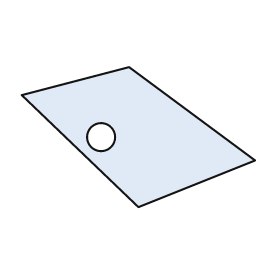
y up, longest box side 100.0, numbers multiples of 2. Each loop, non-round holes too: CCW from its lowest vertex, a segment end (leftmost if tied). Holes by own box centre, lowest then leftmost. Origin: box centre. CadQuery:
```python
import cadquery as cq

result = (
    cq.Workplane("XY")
    .moveTo(0.0, -30.0)
    .lineTo(50.0, -10.0)
    .lineTo(-4.0, 30.0)
    .lineTo(-50.0, 18.0)
    .close()
    .moveTo(-16.0, 0.0)
    .circle(6.0)
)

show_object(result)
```